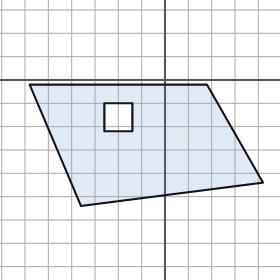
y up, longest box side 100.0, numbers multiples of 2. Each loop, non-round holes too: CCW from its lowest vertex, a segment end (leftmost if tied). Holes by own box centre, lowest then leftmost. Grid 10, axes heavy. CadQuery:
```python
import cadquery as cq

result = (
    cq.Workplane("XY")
    .moveTo(-36.0, -54.0)
    .lineTo(42.0, -44.0)
    .lineTo(18.0, -2.0)
    .lineTo(-58.0, -2.0)
    .close()
    .moveTo(-26.0, -22.0)
    .lineTo(-14.0, -22.0)
    .lineTo(-14.0, -10.0)
    .lineTo(-26.0, -10.0)
    .close()
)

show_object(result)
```